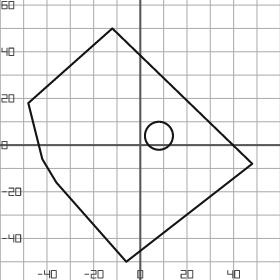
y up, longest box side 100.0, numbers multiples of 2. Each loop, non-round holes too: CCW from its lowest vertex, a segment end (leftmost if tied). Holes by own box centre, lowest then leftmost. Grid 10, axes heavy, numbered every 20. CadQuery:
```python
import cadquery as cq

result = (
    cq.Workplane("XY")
    .moveTo(-6.0, -50.0)
    .lineTo(48.0, -8.0)
    .lineTo(-12.0, 50.0)
    .lineTo(-48.0, 18.0)
    .lineTo(-42.0, -6.0)
    .lineTo(-36.0, -16.0)
    .close()
    .moveTo(8.0, 4.0)
    .circle(6.0)
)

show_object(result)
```